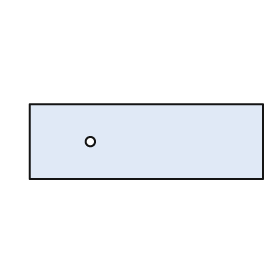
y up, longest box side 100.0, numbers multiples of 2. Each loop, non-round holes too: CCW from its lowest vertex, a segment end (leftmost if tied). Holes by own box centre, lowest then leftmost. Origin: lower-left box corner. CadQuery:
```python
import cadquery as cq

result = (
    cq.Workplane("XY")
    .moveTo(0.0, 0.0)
    .lineTo(100.0, 0.0)
    .lineTo(100.0, 32.0)
    .lineTo(0.0, 32.0)
    .close()
    .moveTo(26.0, 16.0)
    .circle(2.0)
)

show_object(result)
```